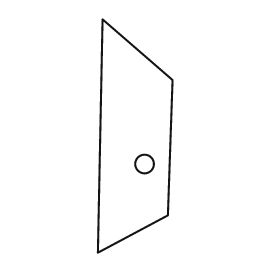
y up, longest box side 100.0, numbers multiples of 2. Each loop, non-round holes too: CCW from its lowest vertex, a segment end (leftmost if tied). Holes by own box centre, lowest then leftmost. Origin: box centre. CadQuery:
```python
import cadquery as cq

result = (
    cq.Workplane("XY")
    .moveTo(-16.0, -50.0)
    .lineTo(14.0, -34.0)
    .lineTo(16.0, 24.0)
    .lineTo(-14.0, 50.0)
    .close()
    .moveTo(4.0, -12.0)
    .circle(4.0)
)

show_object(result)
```